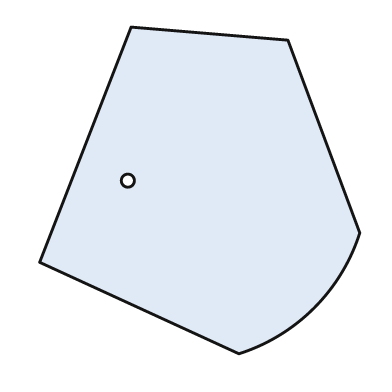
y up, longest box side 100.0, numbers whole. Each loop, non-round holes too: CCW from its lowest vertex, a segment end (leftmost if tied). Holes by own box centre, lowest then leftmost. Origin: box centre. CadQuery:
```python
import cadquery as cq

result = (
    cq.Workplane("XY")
    .moveTo(12.0, -50.0)
    .threePointArc((35.0, -36.0), (49.0, -13.0))
    .lineTo(27.0, 46.0)
    .lineTo(-21.0, 50.0)
    .lineTo(-49.0, -22.0)
    .close()
    .moveTo(-22.0, 3.0)
    .circle(2.0)
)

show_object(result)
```